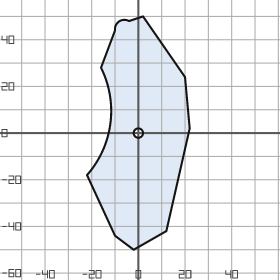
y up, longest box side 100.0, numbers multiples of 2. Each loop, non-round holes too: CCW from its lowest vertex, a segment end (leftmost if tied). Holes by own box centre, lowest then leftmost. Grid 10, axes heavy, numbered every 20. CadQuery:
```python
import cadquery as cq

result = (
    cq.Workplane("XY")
    .moveTo(-2.0, -50.0)
    .lineTo(12.0, -42.0)
    .lineTo(22.0, 2.0)
    .lineTo(20.0, 24.0)
    .lineTo(2.0, 50.0)
    .lineTo(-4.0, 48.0)
    .threePointArc((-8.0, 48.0), (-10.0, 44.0))
    .lineTo(-16.0, 28.0)
    .threePointArc((-12.0, 4.0), (-22.0, -18.0))
    .lineTo(-10.0, -44.0)
    .close()
    .moveTo(0.0, 0.0)
    .circle(2.0)
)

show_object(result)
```